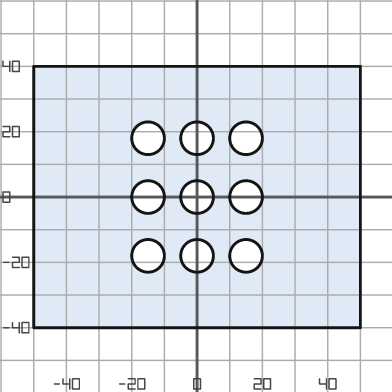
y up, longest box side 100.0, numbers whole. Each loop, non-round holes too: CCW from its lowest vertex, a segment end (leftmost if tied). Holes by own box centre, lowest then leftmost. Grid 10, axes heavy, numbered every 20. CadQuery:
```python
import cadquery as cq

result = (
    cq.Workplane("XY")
    .moveTo(-50.0, -40.0)
    .lineTo(50.0, -40.0)
    .lineTo(50.0, 40.0)
    .lineTo(-50.0, 40.0)
    .close()
    .moveTo(-15.0, -18.0)
    .circle(5.0)
    .moveTo(0.0, -18.0)
    .circle(5.0)
    .moveTo(15.0, -18.0)
    .circle(5.0)
    .moveTo(-15.0, 0.0)
    .circle(5.0)
    .moveTo(0.0, 0.0)
    .circle(5.0)
    .moveTo(15.0, 0.0)
    .circle(5.0)
    .moveTo(-15.0, 18.0)
    .circle(5.0)
    .moveTo(0.0, 18.0)
    .circle(5.0)
    .moveTo(15.0, 18.0)
    .circle(5.0)
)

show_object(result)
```